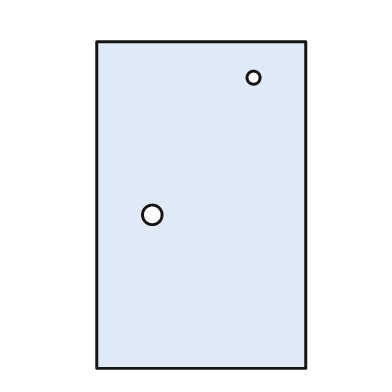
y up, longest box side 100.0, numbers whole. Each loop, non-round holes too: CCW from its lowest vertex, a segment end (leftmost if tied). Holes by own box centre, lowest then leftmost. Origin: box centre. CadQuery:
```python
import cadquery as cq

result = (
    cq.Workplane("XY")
    .moveTo(-32.0, -50.0)
    .lineTo(32.0, -50.0)
    .lineTo(32.0, 50.0)
    .lineTo(-32.0, 50.0)
    .close()
    .moveTo(-15.0, -3.0)
    .circle(3.0)
    .moveTo(16.0, 39.0)
    .circle(2.0)
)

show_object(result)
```